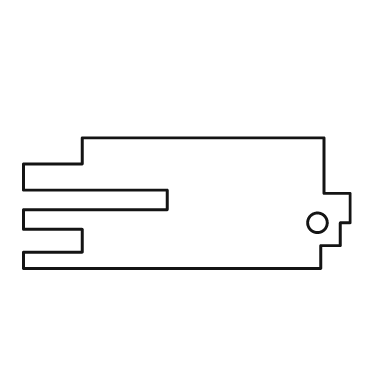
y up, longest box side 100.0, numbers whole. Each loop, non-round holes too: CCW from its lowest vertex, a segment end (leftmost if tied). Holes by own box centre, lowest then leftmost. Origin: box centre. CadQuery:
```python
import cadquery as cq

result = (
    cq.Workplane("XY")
    .moveTo(-50.0, -20.0)
    .lineTo(41.0, -20.0)
    .lineTo(41.0, -13.0)
    .lineTo(47.0, -13.0)
    .lineTo(47.0, -6.0)
    .lineTo(50.0, -6.0)
    .lineTo(50.0, 3.0)
    .lineTo(42.0, 3.0)
    .lineTo(42.0, 20.0)
    .lineTo(-32.0, 20.0)
    .lineTo(-32.0, 12.0)
    .lineTo(-50.0, 12.0)
    .lineTo(-50.0, 4.0)
    .lineTo(-6.0, 4.0)
    .lineTo(-6.0, -2.0)
    .lineTo(-50.0, -2.0)
    .lineTo(-50.0, -8.0)
    .lineTo(-32.0, -8.0)
    .lineTo(-32.0, -15.0)
    .lineTo(-50.0, -15.0)
    .close()
    .moveTo(40.0, -6.0)
    .circle(3.0)
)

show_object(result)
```